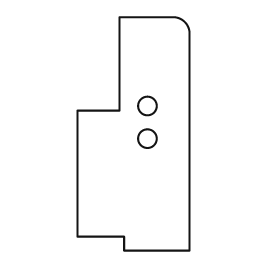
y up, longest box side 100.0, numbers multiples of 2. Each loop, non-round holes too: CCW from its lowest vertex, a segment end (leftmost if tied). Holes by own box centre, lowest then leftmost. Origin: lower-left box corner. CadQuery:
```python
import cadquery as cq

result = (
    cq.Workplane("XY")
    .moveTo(20.0, 0.0)
    .lineTo(48.0, 0.0)
    .lineTo(48.0, 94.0)
    .threePointArc((46.0, 98.0), (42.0, 100.0))
    .lineTo(18.0, 100.0)
    .lineTo(18.0, 60.0)
    .lineTo(0.0, 60.0)
    .lineTo(0.0, 6.0)
    .lineTo(20.0, 6.0)
    .close()
    .moveTo(30.0, 48.0)
    .circle(4.0)
    .moveTo(30.0, 62.0)
    .circle(4.0)
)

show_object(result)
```